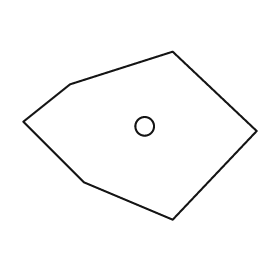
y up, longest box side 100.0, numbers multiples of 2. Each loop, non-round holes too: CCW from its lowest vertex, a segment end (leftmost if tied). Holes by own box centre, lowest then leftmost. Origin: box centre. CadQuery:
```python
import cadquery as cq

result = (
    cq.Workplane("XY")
    .moveTo(14.0, -36.0)
    .lineTo(50.0, 2.0)
    .lineTo(14.0, 36.0)
    .lineTo(-30.0, 22.0)
    .lineTo(-50.0, 6.0)
    .lineTo(-24.0, -20.0)
    .close()
    .moveTo(2.0, 4.0)
    .circle(4.0)
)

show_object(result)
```